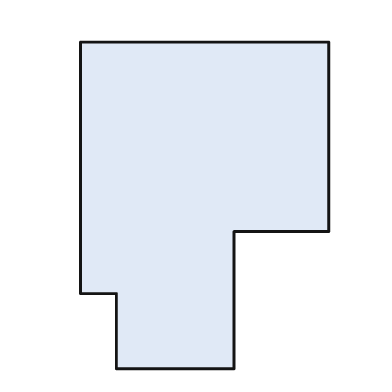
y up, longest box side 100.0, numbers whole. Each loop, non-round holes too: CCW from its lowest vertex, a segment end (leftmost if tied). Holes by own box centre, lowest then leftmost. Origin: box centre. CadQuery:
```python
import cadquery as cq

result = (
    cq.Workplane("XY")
    .moveTo(-27.0, -50.0)
    .lineTo(9.0, -50.0)
    .lineTo(9.0, -8.0)
    .lineTo(38.0, -8.0)
    .lineTo(38.0, 50.0)
    .lineTo(-38.0, 50.0)
    .lineTo(-38.0, -27.0)
    .lineTo(-27.0, -27.0)
    .close()
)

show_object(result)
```